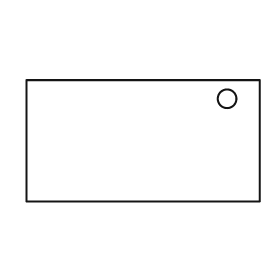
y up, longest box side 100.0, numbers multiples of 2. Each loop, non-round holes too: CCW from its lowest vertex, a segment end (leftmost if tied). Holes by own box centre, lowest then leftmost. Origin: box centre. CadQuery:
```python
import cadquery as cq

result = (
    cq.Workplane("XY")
    .moveTo(-50.0, -26.0)
    .lineTo(50.0, -26.0)
    .lineTo(50.0, 26.0)
    .lineTo(-50.0, 26.0)
    .close()
    .moveTo(36.0, 18.0)
    .circle(4.0)
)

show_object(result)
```